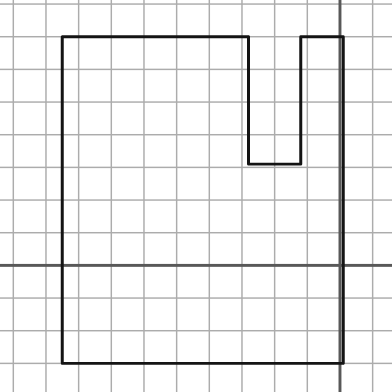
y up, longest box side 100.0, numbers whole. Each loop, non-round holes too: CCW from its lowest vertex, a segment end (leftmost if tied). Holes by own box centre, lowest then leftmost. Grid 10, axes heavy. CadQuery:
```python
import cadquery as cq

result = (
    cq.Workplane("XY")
    .moveTo(-85.0, -30.0)
    .lineTo(1.0, -30.0)
    .lineTo(1.0, 70.0)
    .lineTo(-12.0, 70.0)
    .lineTo(-12.0, 31.0)
    .lineTo(-28.0, 31.0)
    .lineTo(-28.0, 70.0)
    .lineTo(-85.0, 70.0)
    .close()
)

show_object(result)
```